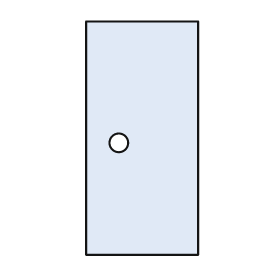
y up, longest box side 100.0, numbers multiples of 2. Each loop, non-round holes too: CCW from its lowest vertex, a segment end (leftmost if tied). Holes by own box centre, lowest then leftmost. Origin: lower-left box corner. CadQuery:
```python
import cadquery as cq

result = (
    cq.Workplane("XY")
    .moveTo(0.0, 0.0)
    .lineTo(48.0, 0.0)
    .lineTo(48.0, 100.0)
    .lineTo(0.0, 100.0)
    .close()
    .moveTo(14.0, 48.0)
    .circle(4.0)
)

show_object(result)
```